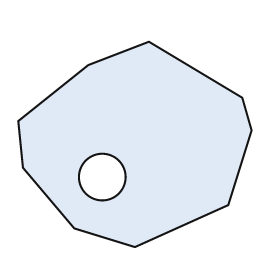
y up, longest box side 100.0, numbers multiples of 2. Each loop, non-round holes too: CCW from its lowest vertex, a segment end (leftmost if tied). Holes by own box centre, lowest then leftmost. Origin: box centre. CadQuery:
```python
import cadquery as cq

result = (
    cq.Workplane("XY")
    .moveTo(0.0, -44.0)
    .lineTo(40.0, -26.0)
    .lineTo(50.0, 6.0)
    .lineTo(46.0, 20.0)
    .lineTo(6.0, 44.0)
    .lineTo(-20.0, 34.0)
    .lineTo(-50.0, 10.0)
    .lineTo(-48.0, -10.0)
    .lineTo(-26.0, -36.0)
    .close()
    .moveTo(-14.0, -14.0)
    .circle(10.0)
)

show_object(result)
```